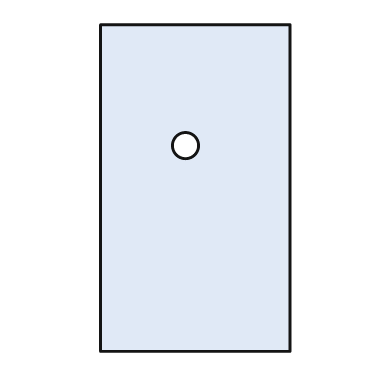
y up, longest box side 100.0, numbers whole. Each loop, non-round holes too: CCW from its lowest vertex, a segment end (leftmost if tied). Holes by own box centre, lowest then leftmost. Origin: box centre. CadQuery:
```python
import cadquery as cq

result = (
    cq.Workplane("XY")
    .moveTo(-29.0, -50.0)
    .lineTo(29.0, -50.0)
    .lineTo(29.0, 50.0)
    .lineTo(-29.0, 50.0)
    .close()
    .moveTo(-3.0, 13.0)
    .circle(4.0)
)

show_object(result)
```